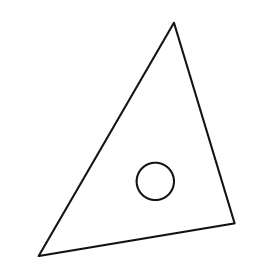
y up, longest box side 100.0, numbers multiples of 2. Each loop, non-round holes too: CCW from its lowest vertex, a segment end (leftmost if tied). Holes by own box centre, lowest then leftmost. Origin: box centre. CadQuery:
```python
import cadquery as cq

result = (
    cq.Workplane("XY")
    .moveTo(-42.0, -50.0)
    .lineTo(42.0, -36.0)
    .lineTo(16.0, 50.0)
    .close()
    .moveTo(8.0, -18.0)
    .circle(8.0)
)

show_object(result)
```